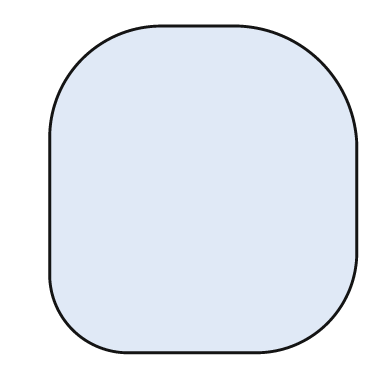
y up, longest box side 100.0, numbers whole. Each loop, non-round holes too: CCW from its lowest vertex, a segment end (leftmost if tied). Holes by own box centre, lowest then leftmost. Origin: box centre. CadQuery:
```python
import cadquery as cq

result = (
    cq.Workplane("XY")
    .moveTo(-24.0, -50.0)
    .lineTo(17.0, -50.0)
    .threePointArc((38.0, -41.0), (47.0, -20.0))
    .lineTo(47.0, 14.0)
    .threePointArc((36.0, 39.0), (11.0, 50.0))
    .lineTo(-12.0, 50.0)
    .threePointArc((-37.0, 40.0), (-47.0, 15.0))
    .lineTo(-47.0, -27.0)
    .threePointArc((-40.0, -43.0), (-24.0, -50.0))
    .close()
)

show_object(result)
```